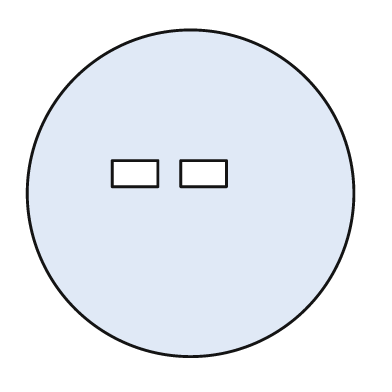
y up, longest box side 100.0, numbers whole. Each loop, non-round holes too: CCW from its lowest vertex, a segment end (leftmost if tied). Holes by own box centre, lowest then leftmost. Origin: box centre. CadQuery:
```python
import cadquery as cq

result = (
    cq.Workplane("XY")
    .moveTo(0.0, 0.0)
    .circle(50.0)
    .moveTo(-24.0, 2.0)
    .lineTo(-10.0, 2.0)
    .lineTo(-10.0, 10.0)
    .lineTo(-24.0, 10.0)
    .close()
    .moveTo(-3.0, 2.0)
    .lineTo(11.0, 2.0)
    .lineTo(11.0, 10.0)
    .lineTo(-3.0, 10.0)
    .close()
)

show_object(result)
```